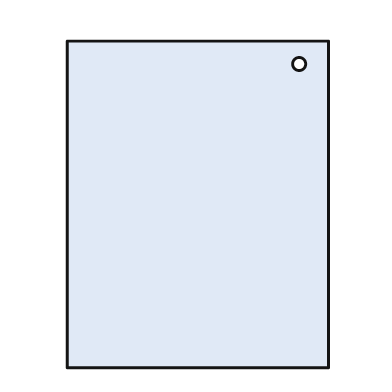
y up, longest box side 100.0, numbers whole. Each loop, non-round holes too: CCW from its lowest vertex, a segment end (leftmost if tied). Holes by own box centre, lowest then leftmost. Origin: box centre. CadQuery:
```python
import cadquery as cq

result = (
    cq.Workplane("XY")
    .moveTo(-40.0, -50.0)
    .lineTo(40.0, -50.0)
    .lineTo(40.0, 50.0)
    .lineTo(-40.0, 50.0)
    .close()
    .moveTo(31.0, 43.0)
    .circle(2.0)
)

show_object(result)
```